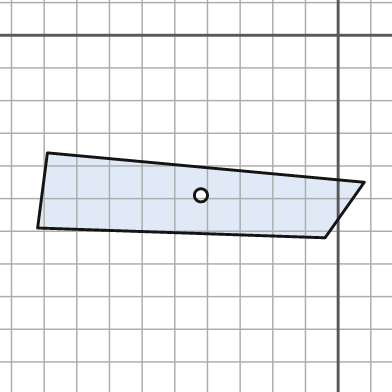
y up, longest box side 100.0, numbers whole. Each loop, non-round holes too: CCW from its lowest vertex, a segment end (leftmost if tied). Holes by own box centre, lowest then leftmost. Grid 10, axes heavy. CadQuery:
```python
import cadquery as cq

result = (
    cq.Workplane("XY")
    .moveTo(-4.0, -62.0)
    .lineTo(8.0, -45.0)
    .lineTo(-89.0, -36.0)
    .lineTo(-92.0, -59.0)
    .close()
    .moveTo(-42.0, -49.0)
    .circle(2.0)
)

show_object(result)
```